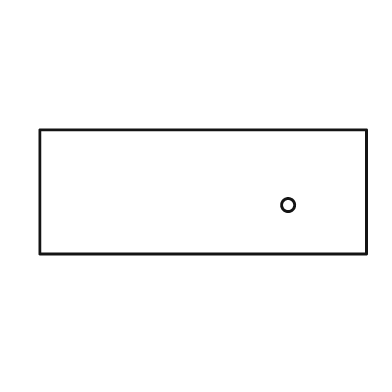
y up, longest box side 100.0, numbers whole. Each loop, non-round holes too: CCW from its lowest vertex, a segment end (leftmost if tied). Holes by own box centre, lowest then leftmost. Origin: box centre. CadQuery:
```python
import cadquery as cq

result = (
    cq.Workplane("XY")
    .moveTo(-50.0, -19.0)
    .lineTo(50.0, -19.0)
    .lineTo(50.0, 19.0)
    .lineTo(-50.0, 19.0)
    .close()
    .moveTo(26.0, -4.0)
    .circle(2.0)
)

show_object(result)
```